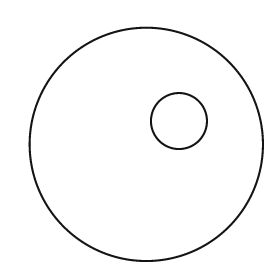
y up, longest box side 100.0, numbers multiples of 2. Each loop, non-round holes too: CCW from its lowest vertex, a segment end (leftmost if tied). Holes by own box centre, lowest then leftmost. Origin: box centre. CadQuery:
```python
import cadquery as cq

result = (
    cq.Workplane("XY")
    .moveTo(0.0, 0.0)
    .circle(50.0)
    .moveTo(14.0, 10.0)
    .circle(12.0)
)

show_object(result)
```